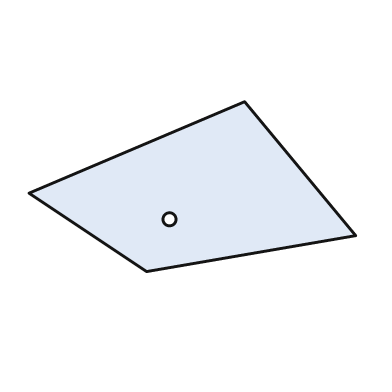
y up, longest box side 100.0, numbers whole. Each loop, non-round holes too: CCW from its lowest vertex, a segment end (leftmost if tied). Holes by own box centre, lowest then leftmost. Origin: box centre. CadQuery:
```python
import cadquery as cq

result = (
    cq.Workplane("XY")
    .moveTo(-14.0, -26.0)
    .lineTo(50.0, -15.0)
    .lineTo(16.0, 26.0)
    .lineTo(-50.0, -2.0)
    .close()
    .moveTo(-7.0, -10.0)
    .circle(2.0)
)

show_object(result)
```